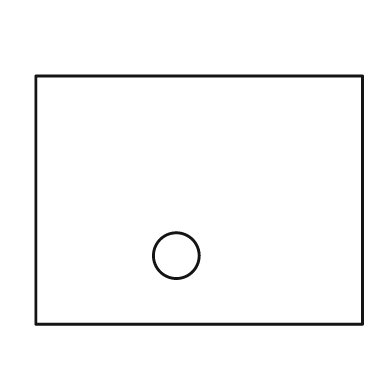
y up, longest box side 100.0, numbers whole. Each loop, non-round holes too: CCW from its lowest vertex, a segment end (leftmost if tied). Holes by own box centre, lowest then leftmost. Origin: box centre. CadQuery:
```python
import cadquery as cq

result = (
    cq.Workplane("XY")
    .moveTo(-50.0, -38.0)
    .lineTo(50.0, -38.0)
    .lineTo(50.0, 38.0)
    .lineTo(-50.0, 38.0)
    .close()
    .moveTo(-7.0, -17.0)
    .circle(7.0)
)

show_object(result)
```